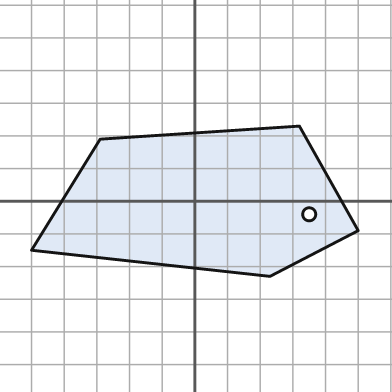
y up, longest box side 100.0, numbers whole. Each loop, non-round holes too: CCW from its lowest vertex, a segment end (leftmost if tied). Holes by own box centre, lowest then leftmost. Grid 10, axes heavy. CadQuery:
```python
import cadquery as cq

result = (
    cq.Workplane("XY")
    .moveTo(23.0, -23.0)
    .lineTo(50.0, -9.0)
    .lineTo(32.0, 23.0)
    .lineTo(-29.0, 19.0)
    .lineTo(-50.0, -15.0)
    .close()
    .moveTo(35.0, -4.0)
    .circle(2.0)
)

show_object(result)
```